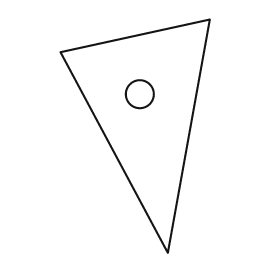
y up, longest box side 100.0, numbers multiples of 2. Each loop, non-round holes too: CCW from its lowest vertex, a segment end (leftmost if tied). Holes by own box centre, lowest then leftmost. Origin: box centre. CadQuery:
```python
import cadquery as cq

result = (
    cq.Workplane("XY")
    .moveTo(14.0, -50.0)
    .lineTo(32.0, 50.0)
    .lineTo(-32.0, 36.0)
    .close()
    .moveTo(2.0, 18.0)
    .circle(6.0)
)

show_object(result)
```